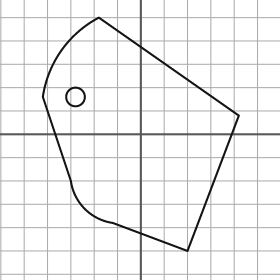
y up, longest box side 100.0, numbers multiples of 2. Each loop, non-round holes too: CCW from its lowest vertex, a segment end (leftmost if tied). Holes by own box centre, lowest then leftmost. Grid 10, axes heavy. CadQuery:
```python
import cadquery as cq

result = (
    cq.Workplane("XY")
    .moveTo(20.0, -50.0)
    .lineTo(42.0, 8.0)
    .lineTo(-18.0, 50.0)
    .threePointArc((-34.0, 36.0), (-42.0, 16.0))
    .lineTo(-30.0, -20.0)
    .threePointArc((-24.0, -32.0), (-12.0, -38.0))
    .close()
    .moveTo(-28.0, 16.0)
    .circle(4.0)
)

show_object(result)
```